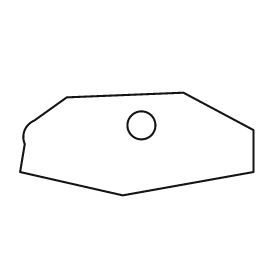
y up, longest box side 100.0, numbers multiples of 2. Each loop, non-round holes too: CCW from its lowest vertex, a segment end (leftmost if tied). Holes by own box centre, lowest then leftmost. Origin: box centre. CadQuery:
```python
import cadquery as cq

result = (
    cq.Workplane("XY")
    .moveTo(-6.0, -22.0)
    .lineTo(50.0, -12.0)
    .lineTo(50.0, 6.0)
    .lineTo(20.0, 22.0)
    .lineTo(-30.0, 20.0)
    .lineTo(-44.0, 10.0)
    .threePointArc((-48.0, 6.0), (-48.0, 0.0))
    .lineTo(-50.0, -12.0)
    .close()
    .moveTo(2.0, 8.0)
    .circle(6.0)
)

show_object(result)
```